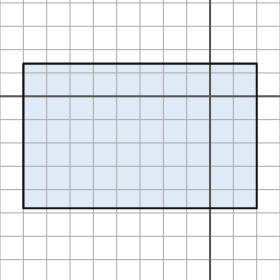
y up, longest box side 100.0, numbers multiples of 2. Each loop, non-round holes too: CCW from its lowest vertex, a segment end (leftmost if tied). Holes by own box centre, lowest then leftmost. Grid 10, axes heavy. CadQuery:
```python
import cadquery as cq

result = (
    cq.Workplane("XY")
    .moveTo(-80.0, -48.0)
    .lineTo(20.0, -48.0)
    .lineTo(20.0, 14.0)
    .lineTo(-80.0, 14.0)
    .close()
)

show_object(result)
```